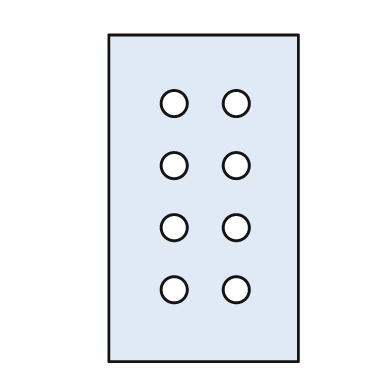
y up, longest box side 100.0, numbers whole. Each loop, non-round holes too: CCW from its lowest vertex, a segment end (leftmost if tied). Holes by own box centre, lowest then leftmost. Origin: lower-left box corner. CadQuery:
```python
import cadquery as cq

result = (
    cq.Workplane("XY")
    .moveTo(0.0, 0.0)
    .lineTo(58.0, 0.0)
    .lineTo(58.0, 100.0)
    .lineTo(0.0, 100.0)
    .close()
    .moveTo(20.0, 22.0)
    .circle(4.0)
    .moveTo(39.0, 22.0)
    .circle(4.0)
    .moveTo(20.0, 41.0)
    .circle(4.0)
    .moveTo(39.0, 41.0)
    .circle(4.0)
    .moveTo(20.0, 60.0)
    .circle(4.0)
    .moveTo(39.0, 60.0)
    .circle(4.0)
    .moveTo(20.0, 79.0)
    .circle(4.0)
    .moveTo(39.0, 79.0)
    .circle(4.0)
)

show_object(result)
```